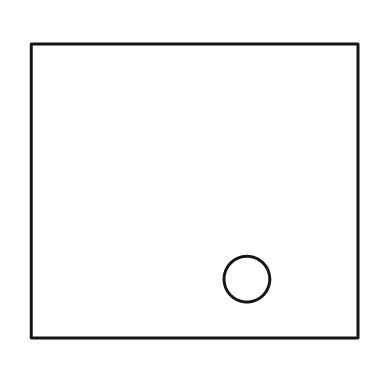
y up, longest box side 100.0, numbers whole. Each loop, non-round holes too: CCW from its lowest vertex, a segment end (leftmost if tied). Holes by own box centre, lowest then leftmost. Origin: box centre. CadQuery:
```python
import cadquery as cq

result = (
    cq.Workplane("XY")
    .moveTo(-50.0, -45.0)
    .lineTo(50.0, -45.0)
    .lineTo(50.0, 45.0)
    .lineTo(-50.0, 45.0)
    .close()
    .moveTo(16.0, -27.0)
    .circle(7.0)
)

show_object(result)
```